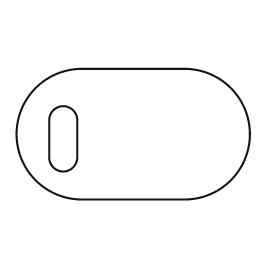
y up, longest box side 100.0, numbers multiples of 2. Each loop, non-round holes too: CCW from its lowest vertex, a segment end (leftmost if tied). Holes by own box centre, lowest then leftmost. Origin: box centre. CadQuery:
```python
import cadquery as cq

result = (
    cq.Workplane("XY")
    .moveTo(-22.0, -28.0)
    .lineTo(22.0, -28.0)
    .threePointArc((50.0, 0.0), (22.0, 28.0))
    .lineTo(-22.0, 28.0)
    .threePointArc((-50.0, 0.0), (-22.0, -28.0))
    .close()
    .moveTo(-36.0, -10.0)
    .threePointArc((-30.0, -16.0), (-24.0, -10.0))
    .lineTo(-24.0, 6.0)
    .threePointArc((-30.0, 12.0), (-36.0, 6.0))
    .close()
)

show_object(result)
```